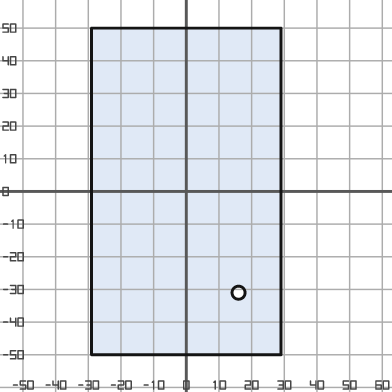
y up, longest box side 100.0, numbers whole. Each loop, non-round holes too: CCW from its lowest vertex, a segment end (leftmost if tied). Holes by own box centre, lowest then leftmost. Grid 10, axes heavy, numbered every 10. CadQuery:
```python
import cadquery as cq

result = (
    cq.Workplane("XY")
    .moveTo(-29.0, -50.0)
    .lineTo(29.0, -50.0)
    .lineTo(29.0, 50.0)
    .lineTo(-29.0, 50.0)
    .close()
    .moveTo(16.0, -31.0)
    .circle(2.0)
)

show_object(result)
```